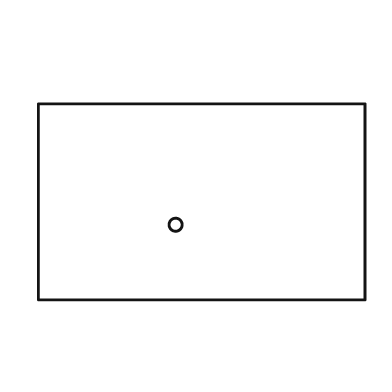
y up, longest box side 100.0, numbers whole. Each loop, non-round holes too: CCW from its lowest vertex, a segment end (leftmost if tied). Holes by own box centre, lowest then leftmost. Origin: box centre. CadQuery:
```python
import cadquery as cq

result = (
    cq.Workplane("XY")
    .moveTo(-50.0, -30.0)
    .lineTo(50.0, -30.0)
    .lineTo(50.0, 30.0)
    .lineTo(-50.0, 30.0)
    .close()
    .moveTo(-8.0, -7.0)
    .circle(2.0)
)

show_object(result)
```